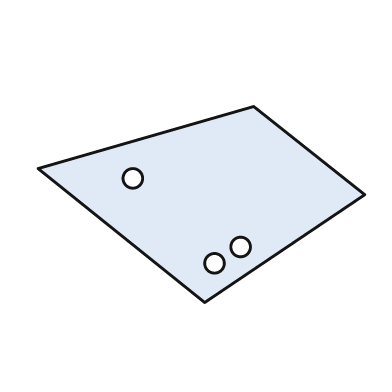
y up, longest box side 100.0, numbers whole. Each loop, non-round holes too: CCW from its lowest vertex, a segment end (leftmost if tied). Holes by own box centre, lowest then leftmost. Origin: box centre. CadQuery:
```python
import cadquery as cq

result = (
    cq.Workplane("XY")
    .moveTo(1.0, -30.0)
    .lineTo(50.0, 3.0)
    .lineTo(16.0, 30.0)
    .lineTo(-50.0, 11.0)
    .close()
    .moveTo(4.0, -18.0)
    .circle(3.0)
    .moveTo(12.0, -13.0)
    .circle(3.0)
    .moveTo(-21.0, 8.0)
    .circle(3.0)
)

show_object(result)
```